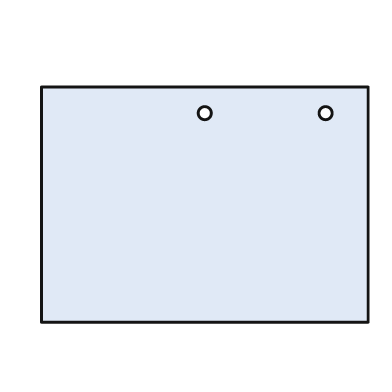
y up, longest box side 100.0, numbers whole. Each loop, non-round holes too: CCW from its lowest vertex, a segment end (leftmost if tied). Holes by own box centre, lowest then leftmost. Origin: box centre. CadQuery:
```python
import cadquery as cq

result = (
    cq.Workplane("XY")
    .moveTo(-50.0, -36.0)
    .lineTo(50.0, -36.0)
    .lineTo(50.0, 36.0)
    .lineTo(-50.0, 36.0)
    .close()
    .moveTo(0.0, 28.0)
    .circle(2.0)
    .moveTo(37.0, 28.0)
    .circle(2.0)
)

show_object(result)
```